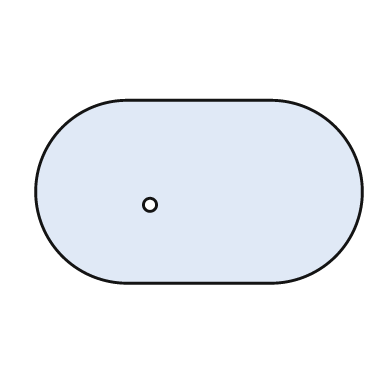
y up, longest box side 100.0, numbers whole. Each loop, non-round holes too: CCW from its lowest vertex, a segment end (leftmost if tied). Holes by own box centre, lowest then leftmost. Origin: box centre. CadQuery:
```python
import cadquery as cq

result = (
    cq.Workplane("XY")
    .moveTo(-22.0, -28.0)
    .lineTo(22.0, -28.0)
    .threePointArc((50.0, 0.0), (22.0, 28.0))
    .lineTo(-22.0, 28.0)
    .threePointArc((-50.0, 0.0), (-22.0, -28.0))
    .close()
    .moveTo(-15.0, -4.0)
    .circle(2.0)
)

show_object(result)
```